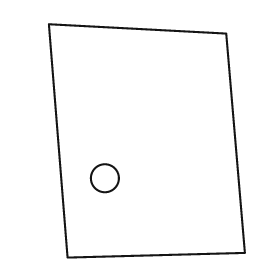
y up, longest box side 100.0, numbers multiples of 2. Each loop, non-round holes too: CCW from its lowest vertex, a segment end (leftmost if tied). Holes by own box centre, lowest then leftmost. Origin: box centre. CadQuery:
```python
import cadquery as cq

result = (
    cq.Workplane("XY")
    .moveTo(-34.0, -50.0)
    .lineTo(42.0, -48.0)
    .lineTo(34.0, 46.0)
    .lineTo(-42.0, 50.0)
    .close()
    .moveTo(-18.0, -16.0)
    .circle(6.0)
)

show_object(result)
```